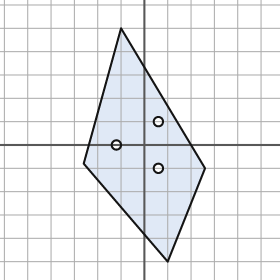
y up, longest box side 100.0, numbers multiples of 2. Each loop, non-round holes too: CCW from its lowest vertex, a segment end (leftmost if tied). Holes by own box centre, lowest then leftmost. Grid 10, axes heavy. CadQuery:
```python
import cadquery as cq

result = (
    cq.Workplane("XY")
    .moveTo(10.0, -50.0)
    .lineTo(26.0, -10.0)
    .lineTo(-10.0, 50.0)
    .lineTo(-26.0, -8.0)
    .close()
    .moveTo(6.0, -10.0)
    .circle(2.0)
    .moveTo(-12.0, 0.0)
    .circle(2.0)
    .moveTo(6.0, 10.0)
    .circle(2.0)
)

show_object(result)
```